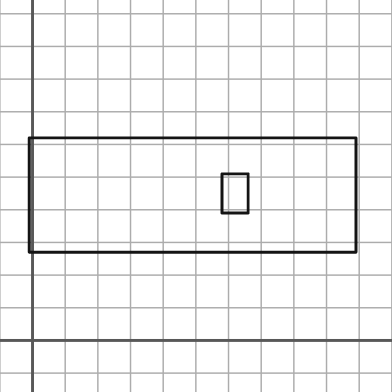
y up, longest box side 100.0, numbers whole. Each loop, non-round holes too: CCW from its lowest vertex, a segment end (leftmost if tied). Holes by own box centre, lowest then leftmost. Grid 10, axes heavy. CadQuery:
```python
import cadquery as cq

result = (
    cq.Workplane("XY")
    .moveTo(-1.0, 27.0)
    .lineTo(99.0, 27.0)
    .lineTo(99.0, 62.0)
    .lineTo(-1.0, 62.0)
    .close()
    .moveTo(58.0, 39.0)
    .lineTo(66.0, 39.0)
    .lineTo(66.0, 51.0)
    .lineTo(58.0, 51.0)
    .close()
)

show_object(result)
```